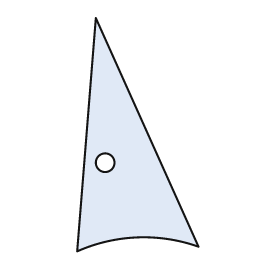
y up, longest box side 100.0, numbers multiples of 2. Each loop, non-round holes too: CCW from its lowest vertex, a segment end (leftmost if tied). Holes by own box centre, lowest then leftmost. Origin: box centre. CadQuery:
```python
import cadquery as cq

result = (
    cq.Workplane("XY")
    .moveTo(-26.0, -50.0)
    .threePointArc((0.0, -44.0), (26.0, -48.0))
    .lineTo(-18.0, 50.0)
    .close()
    .moveTo(-14.0, -12.0)
    .circle(4.0)
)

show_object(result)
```